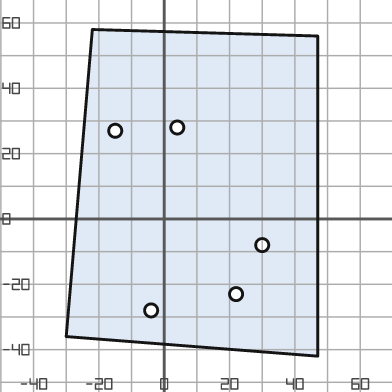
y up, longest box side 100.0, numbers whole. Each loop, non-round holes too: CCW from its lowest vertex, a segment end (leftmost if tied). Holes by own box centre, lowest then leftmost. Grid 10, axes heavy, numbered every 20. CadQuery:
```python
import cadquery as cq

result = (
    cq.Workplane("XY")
    .moveTo(47.0, -42.0)
    .lineTo(47.0, 56.0)
    .lineTo(-22.0, 58.0)
    .lineTo(-30.0, -36.0)
    .close()
    .moveTo(-4.0, -28.0)
    .circle(2.0)
    .moveTo(22.0, -23.0)
    .circle(2.0)
    .moveTo(30.0, -8.0)
    .circle(2.0)
    .moveTo(-15.0, 27.0)
    .circle(2.0)
    .moveTo(4.0, 28.0)
    .circle(2.0)
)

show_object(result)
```